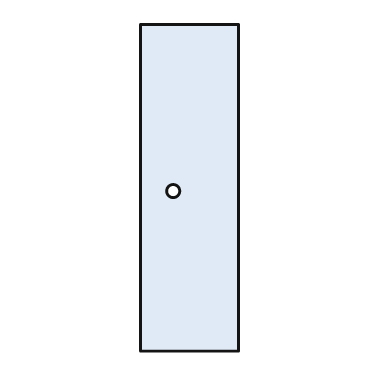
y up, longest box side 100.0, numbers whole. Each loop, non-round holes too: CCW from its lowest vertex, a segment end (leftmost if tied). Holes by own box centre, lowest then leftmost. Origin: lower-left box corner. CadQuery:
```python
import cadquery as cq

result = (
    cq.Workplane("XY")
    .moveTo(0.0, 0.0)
    .lineTo(30.0, 0.0)
    .lineTo(30.0, 100.0)
    .lineTo(0.0, 100.0)
    .close()
    .moveTo(10.0, 49.0)
    .circle(2.0)
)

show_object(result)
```